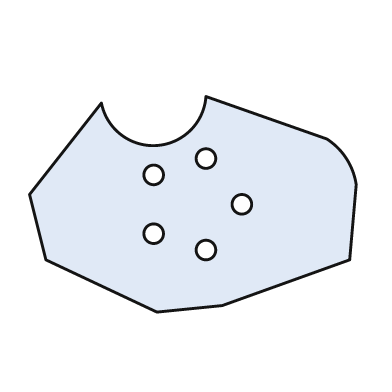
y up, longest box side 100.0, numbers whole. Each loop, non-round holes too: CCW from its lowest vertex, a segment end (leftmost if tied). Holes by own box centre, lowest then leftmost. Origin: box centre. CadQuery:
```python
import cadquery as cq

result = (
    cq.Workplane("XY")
    .moveTo(-11.0, -33.0)
    .lineTo(9.0, -31.0)
    .lineTo(48.0, -17.0)
    .lineTo(50.0, 6.0)
    .threePointArc((47.0, 14.0), (41.0, 20.0))
    .lineTo(4.0, 33.0)
    .threePointArc((-11.0, 18.0), (-28.0, 31.0))
    .lineTo(-50.0, 3.0)
    .lineTo(-45.0, -17.0)
    .close()
    .moveTo(4.0, -14.0)
    .circle(3.0)
    .moveTo(-12.0, -9.0)
    .circle(3.0)
    .moveTo(15.0, 0.0)
    .circle(3.0)
    .moveTo(-12.0, 9.0)
    .circle(3.0)
    .moveTo(4.0, 14.0)
    .circle(3.0)
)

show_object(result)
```